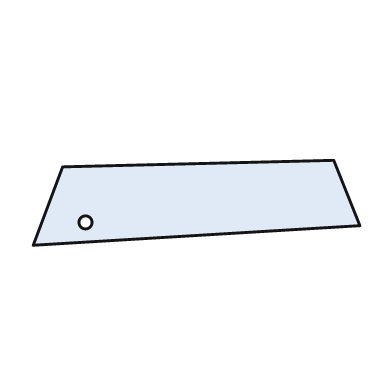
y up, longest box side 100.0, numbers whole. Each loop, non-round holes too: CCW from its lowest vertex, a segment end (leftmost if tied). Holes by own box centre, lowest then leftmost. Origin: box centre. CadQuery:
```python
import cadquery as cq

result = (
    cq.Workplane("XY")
    .moveTo(-50.0, -13.0)
    .lineTo(50.0, -7.0)
    .lineTo(42.0, 13.0)
    .lineTo(-41.0, 11.0)
    .close()
    .moveTo(-34.0, -6.0)
    .circle(2.0)
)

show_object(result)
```